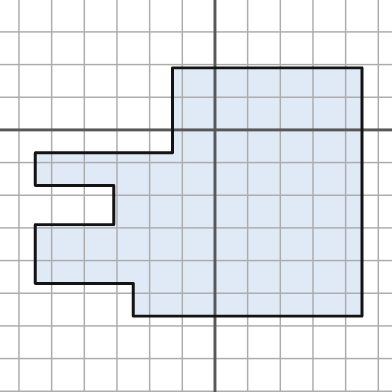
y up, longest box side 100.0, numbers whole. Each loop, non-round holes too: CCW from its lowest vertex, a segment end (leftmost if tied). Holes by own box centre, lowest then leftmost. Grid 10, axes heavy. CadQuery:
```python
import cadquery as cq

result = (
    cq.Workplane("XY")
    .moveTo(-25.0, -57.0)
    .lineTo(45.0, -57.0)
    .lineTo(45.0, 19.0)
    .lineTo(-13.0, 19.0)
    .lineTo(-13.0, -7.0)
    .lineTo(-55.0, -7.0)
    .lineTo(-55.0, -17.0)
    .lineTo(-31.0, -17.0)
    .lineTo(-31.0, -29.0)
    .lineTo(-55.0, -29.0)
    .lineTo(-55.0, -47.0)
    .lineTo(-25.0, -47.0)
    .close()
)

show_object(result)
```